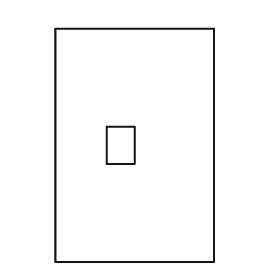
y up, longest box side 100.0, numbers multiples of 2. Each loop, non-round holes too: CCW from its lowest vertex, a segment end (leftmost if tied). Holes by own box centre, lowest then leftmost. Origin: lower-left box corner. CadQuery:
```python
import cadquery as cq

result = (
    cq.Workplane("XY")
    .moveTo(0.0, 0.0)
    .lineTo(68.0, 0.0)
    .lineTo(68.0, 100.0)
    .lineTo(0.0, 100.0)
    .close()
    .moveTo(22.0, 42.0)
    .lineTo(34.0, 42.0)
    .lineTo(34.0, 58.0)
    .lineTo(22.0, 58.0)
    .close()
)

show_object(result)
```